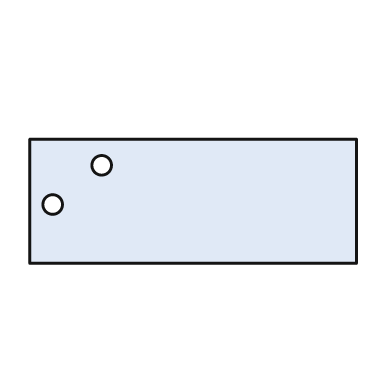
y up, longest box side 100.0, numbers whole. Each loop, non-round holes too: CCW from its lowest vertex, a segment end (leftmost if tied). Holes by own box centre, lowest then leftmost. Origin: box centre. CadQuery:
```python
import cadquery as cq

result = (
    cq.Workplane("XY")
    .moveTo(-50.0, -19.0)
    .lineTo(50.0, -19.0)
    .lineTo(50.0, 19.0)
    .lineTo(-50.0, 19.0)
    .close()
    .moveTo(-43.0, -1.0)
    .circle(3.0)
    .moveTo(-28.0, 11.0)
    .circle(3.0)
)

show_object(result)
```